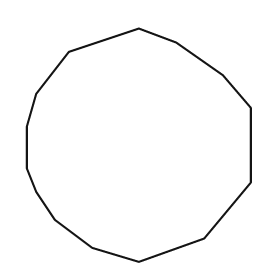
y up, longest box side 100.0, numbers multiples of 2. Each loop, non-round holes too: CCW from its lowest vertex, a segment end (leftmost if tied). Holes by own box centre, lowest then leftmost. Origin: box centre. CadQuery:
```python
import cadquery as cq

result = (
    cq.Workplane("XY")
    .moveTo(0.0, -50.0)
    .lineTo(28.0, -40.0)
    .lineTo(48.0, -16.0)
    .lineTo(48.0, 16.0)
    .lineTo(36.0, 30.0)
    .lineTo(16.0, 44.0)
    .lineTo(0.0, 50.0)
    .lineTo(-30.0, 40.0)
    .lineTo(-44.0, 22.0)
    .lineTo(-48.0, 8.0)
    .lineTo(-48.0, -10.0)
    .lineTo(-44.0, -20.0)
    .lineTo(-36.0, -32.0)
    .lineTo(-20.0, -44.0)
    .close()
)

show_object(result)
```